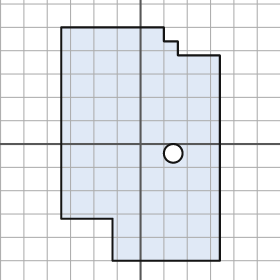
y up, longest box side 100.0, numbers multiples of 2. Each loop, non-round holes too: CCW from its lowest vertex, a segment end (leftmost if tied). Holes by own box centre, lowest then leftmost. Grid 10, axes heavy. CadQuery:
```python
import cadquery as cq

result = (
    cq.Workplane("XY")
    .moveTo(-12.0, -50.0)
    .lineTo(34.0, -50.0)
    .lineTo(34.0, 38.0)
    .lineTo(16.0, 38.0)
    .lineTo(16.0, 44.0)
    .lineTo(10.0, 44.0)
    .lineTo(10.0, 50.0)
    .lineTo(-34.0, 50.0)
    .lineTo(-34.0, -32.0)
    .lineTo(-12.0, -32.0)
    .close()
    .moveTo(14.0, -4.0)
    .circle(4.0)
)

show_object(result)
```